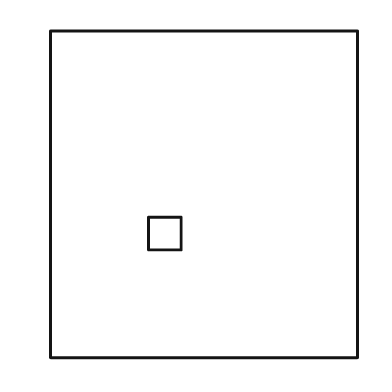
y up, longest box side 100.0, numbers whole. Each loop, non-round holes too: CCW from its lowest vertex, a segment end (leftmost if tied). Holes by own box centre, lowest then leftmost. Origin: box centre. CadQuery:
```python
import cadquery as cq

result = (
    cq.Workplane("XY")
    .moveTo(-47.0, -50.0)
    .lineTo(47.0, -50.0)
    .lineTo(47.0, 50.0)
    .lineTo(-47.0, 50.0)
    .close()
    .moveTo(-17.0, -17.0)
    .lineTo(-7.0, -17.0)
    .lineTo(-7.0, -7.0)
    .lineTo(-17.0, -7.0)
    .close()
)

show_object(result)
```